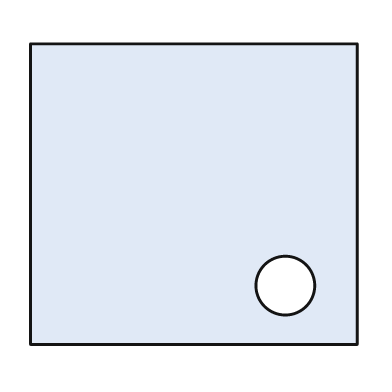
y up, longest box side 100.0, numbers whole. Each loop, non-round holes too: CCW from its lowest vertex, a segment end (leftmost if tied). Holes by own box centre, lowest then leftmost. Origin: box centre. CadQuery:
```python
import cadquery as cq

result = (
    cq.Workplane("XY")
    .moveTo(-50.0, -46.0)
    .lineTo(50.0, -46.0)
    .lineTo(50.0, 46.0)
    .lineTo(-50.0, 46.0)
    .close()
    .moveTo(28.0, -28.0)
    .circle(9.0)
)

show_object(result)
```